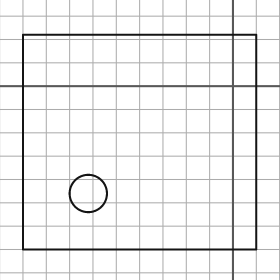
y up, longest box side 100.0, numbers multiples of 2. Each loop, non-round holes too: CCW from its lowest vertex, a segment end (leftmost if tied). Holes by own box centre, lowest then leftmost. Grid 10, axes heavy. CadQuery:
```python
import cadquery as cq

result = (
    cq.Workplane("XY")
    .moveTo(-90.0, -70.0)
    .lineTo(10.0, -70.0)
    .lineTo(10.0, 22.0)
    .lineTo(-90.0, 22.0)
    .close()
    .moveTo(-62.0, -46.0)
    .circle(8.0)
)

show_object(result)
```